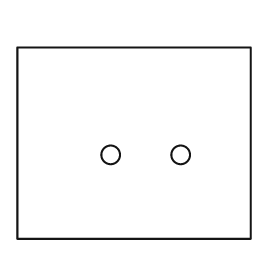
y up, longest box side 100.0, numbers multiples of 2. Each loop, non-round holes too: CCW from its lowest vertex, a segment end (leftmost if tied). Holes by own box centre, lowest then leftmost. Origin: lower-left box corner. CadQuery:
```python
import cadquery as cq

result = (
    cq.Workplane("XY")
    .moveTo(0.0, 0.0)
    .lineTo(100.0, 0.0)
    .lineTo(100.0, 82.0)
    .lineTo(0.0, 82.0)
    .close()
    .moveTo(40.0, 36.0)
    .circle(4.0)
    .moveTo(70.0, 36.0)
    .circle(4.0)
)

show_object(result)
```